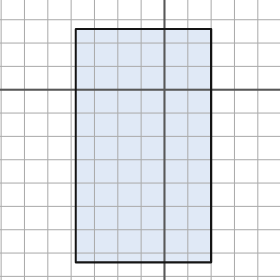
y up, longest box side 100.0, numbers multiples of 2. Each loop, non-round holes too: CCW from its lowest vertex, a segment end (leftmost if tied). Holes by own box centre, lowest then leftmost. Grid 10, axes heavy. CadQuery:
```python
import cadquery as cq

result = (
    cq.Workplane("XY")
    .moveTo(-38.0, -74.0)
    .lineTo(20.0, -74.0)
    .lineTo(20.0, 26.0)
    .lineTo(-38.0, 26.0)
    .close()
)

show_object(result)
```